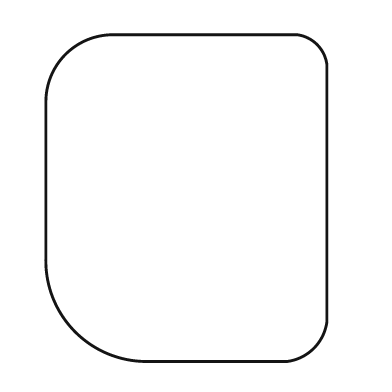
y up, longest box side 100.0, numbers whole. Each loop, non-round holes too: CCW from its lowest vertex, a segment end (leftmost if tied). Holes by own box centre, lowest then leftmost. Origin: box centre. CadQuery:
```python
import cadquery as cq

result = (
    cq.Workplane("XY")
    .moveTo(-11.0, -50.0)
    .lineTo(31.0, -50.0)
    .threePointArc((39.0, -46.0), (43.0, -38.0))
    .lineTo(43.0, 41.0)
    .threePointArc((40.0, 47.0), (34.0, 50.0))
    .lineTo(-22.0, 50.0)
    .threePointArc((-37.0, 44.0), (-43.0, 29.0))
    .lineTo(-43.0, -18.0)
    .threePointArc((-34.0, -41.0), (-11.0, -50.0))
    .close()
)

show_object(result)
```